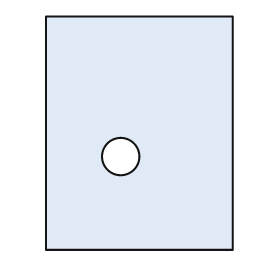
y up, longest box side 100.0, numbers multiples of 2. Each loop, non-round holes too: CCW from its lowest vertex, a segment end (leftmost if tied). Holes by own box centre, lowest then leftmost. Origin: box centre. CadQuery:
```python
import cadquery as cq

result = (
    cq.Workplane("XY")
    .moveTo(-40.0, -50.0)
    .lineTo(40.0, -50.0)
    .lineTo(40.0, 50.0)
    .lineTo(-40.0, 50.0)
    .close()
    .moveTo(-8.0, -10.0)
    .circle(8.0)
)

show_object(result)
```